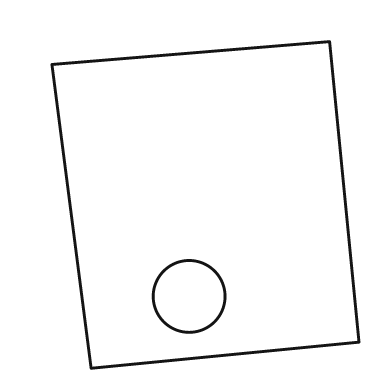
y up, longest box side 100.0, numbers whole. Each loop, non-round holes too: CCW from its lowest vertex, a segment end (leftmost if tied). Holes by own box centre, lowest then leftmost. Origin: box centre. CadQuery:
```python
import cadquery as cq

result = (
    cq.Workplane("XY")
    .moveTo(-35.0, -50.0)
    .lineTo(47.0, -42.0)
    .lineTo(38.0, 50.0)
    .lineTo(-47.0, 43.0)
    .close()
    .moveTo(-5.0, -28.0)
    .circle(11.0)
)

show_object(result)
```